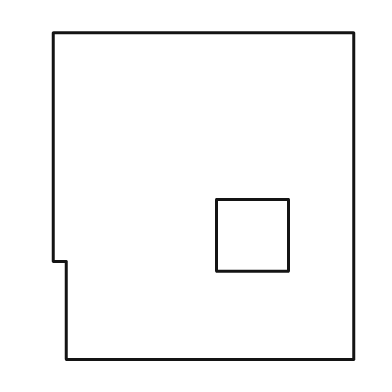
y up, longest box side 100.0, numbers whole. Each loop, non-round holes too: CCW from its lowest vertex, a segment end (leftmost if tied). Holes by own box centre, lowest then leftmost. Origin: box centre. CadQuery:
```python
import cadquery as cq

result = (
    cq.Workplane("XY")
    .moveTo(-42.0, -50.0)
    .lineTo(46.0, -50.0)
    .lineTo(46.0, 50.0)
    .lineTo(-46.0, 50.0)
    .lineTo(-46.0, -20.0)
    .lineTo(-42.0, -20.0)
    .close()
    .moveTo(4.0, -23.0)
    .lineTo(26.0, -23.0)
    .lineTo(26.0, -1.0)
    .lineTo(4.0, -1.0)
    .close()
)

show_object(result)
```